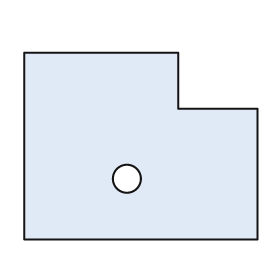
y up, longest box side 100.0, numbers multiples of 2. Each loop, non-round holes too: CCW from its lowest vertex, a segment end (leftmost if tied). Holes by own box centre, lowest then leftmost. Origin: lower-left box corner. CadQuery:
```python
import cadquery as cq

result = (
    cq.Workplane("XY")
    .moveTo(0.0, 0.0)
    .lineTo(100.0, 0.0)
    .lineTo(100.0, 56.0)
    .lineTo(66.0, 56.0)
    .lineTo(66.0, 80.0)
    .lineTo(0.0, 80.0)
    .close()
    .moveTo(44.0, 26.0)
    .circle(6.0)
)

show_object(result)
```